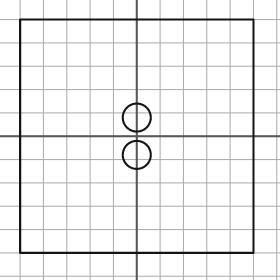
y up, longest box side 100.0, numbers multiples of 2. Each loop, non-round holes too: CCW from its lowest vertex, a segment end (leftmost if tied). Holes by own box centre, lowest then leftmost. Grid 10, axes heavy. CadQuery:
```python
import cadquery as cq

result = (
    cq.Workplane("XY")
    .moveTo(-50.0, -50.0)
    .lineTo(50.0, -50.0)
    .lineTo(50.0, 50.0)
    .lineTo(-50.0, 50.0)
    .close()
    .moveTo(0.0, -8.0)
    .circle(6.0)
    .moveTo(0.0, 8.0)
    .circle(6.0)
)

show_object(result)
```